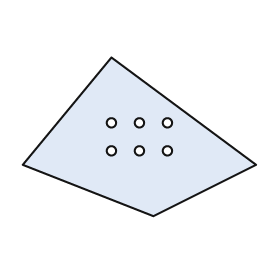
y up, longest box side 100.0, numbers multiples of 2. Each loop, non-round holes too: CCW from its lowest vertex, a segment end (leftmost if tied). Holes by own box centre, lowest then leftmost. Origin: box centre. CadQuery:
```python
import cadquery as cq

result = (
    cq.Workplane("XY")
    .moveTo(6.0, -34.0)
    .lineTo(50.0, -12.0)
    .lineTo(-12.0, 34.0)
    .lineTo(-50.0, -12.0)
    .close()
    .moveTo(-12.0, -6.0)
    .circle(2.0)
    .moveTo(0.0, -6.0)
    .circle(2.0)
    .moveTo(12.0, -6.0)
    .circle(2.0)
    .moveTo(-12.0, 6.0)
    .circle(2.0)
    .moveTo(0.0, 6.0)
    .circle(2.0)
    .moveTo(12.0, 6.0)
    .circle(2.0)
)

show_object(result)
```